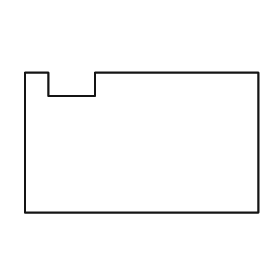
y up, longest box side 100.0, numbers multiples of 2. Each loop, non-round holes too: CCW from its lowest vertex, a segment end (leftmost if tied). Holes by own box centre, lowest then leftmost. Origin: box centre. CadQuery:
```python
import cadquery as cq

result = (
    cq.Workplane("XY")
    .moveTo(-50.0, -30.0)
    .lineTo(50.0, -30.0)
    .lineTo(50.0, 30.0)
    .lineTo(-20.0, 30.0)
    .lineTo(-20.0, 20.0)
    .lineTo(-40.0, 20.0)
    .lineTo(-40.0, 30.0)
    .lineTo(-50.0, 30.0)
    .close()
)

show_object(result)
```